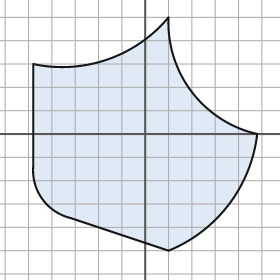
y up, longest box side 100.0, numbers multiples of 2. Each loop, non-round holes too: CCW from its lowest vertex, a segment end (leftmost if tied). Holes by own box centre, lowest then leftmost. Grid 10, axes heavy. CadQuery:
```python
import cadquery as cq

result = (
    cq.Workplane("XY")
    .moveTo(10.0, -50.0)
    .threePointArc((36.0, -30.0), (48.0, 0.0))
    .threePointArc((20.0, 18.0), (10.0, 50.0))
    .threePointArc((-16.0, 32.0), (-48.0, 30.0))
    .lineTo(-48.0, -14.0)
    .threePointArc((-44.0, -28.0), (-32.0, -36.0))
    .close()
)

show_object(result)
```